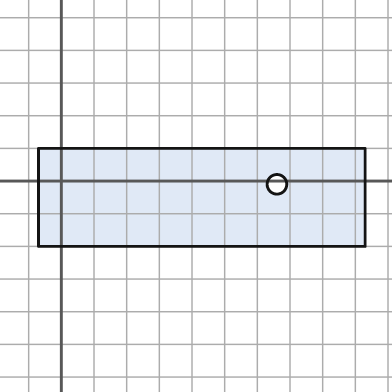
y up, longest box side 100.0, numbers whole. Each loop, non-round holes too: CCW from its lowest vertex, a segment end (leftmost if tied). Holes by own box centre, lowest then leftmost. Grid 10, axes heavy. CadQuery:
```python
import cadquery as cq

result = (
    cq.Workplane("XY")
    .moveTo(-7.0, -20.0)
    .lineTo(93.0, -20.0)
    .lineTo(93.0, 10.0)
    .lineTo(-7.0, 10.0)
    .close()
    .moveTo(66.0, -1.0)
    .circle(3.0)
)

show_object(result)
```